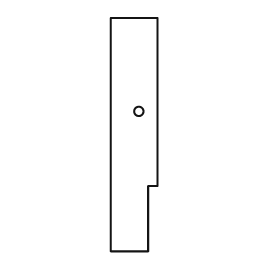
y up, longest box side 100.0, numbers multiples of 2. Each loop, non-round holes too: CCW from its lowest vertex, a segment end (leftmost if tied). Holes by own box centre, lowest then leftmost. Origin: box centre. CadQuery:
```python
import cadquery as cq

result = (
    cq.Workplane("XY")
    .moveTo(-10.0, -50.0)
    .lineTo(6.0, -50.0)
    .lineTo(6.0, -22.0)
    .lineTo(10.0, -22.0)
    .lineTo(10.0, 50.0)
    .lineTo(-10.0, 50.0)
    .close()
    .moveTo(2.0, 10.0)
    .circle(2.0)
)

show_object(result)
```